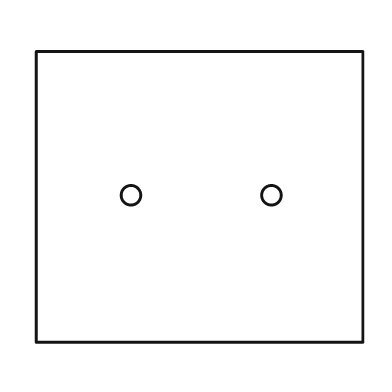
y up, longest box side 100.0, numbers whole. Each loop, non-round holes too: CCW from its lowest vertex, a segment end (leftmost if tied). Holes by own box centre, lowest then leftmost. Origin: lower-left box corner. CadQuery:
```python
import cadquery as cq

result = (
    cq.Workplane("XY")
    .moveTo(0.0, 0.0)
    .lineTo(100.0, 0.0)
    .lineTo(100.0, 89.0)
    .lineTo(0.0, 89.0)
    .close()
    .moveTo(29.0, 45.0)
    .circle(3.0)
    .moveTo(72.0, 45.0)
    .circle(3.0)
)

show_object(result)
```